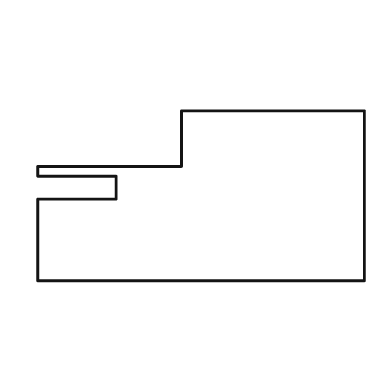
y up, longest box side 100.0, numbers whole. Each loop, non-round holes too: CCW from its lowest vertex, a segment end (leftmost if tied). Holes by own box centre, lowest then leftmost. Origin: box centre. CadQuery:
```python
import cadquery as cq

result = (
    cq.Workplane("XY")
    .moveTo(-50.0, -26.0)
    .lineTo(50.0, -26.0)
    .lineTo(50.0, 26.0)
    .lineTo(-6.0, 26.0)
    .lineTo(-6.0, 9.0)
    .lineTo(-50.0, 9.0)
    .lineTo(-50.0, 6.0)
    .lineTo(-26.0, 6.0)
    .lineTo(-26.0, -1.0)
    .lineTo(-50.0, -1.0)
    .close()
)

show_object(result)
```